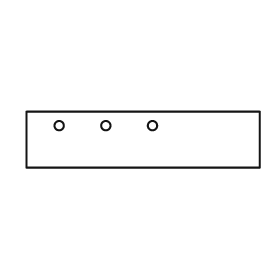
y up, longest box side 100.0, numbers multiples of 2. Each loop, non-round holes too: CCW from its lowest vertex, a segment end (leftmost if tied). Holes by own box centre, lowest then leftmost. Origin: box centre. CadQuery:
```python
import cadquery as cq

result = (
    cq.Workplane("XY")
    .moveTo(-50.0, -12.0)
    .lineTo(50.0, -12.0)
    .lineTo(50.0, 12.0)
    .lineTo(-50.0, 12.0)
    .close()
    .moveTo(-36.0, 6.0)
    .circle(2.0)
    .moveTo(-16.0, 6.0)
    .circle(2.0)
    .moveTo(4.0, 6.0)
    .circle(2.0)
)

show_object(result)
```